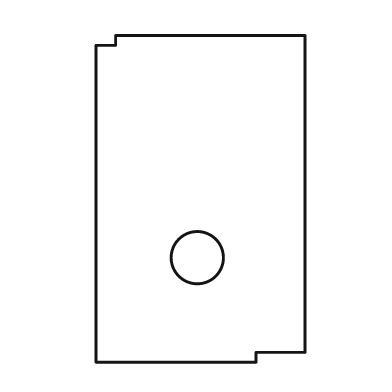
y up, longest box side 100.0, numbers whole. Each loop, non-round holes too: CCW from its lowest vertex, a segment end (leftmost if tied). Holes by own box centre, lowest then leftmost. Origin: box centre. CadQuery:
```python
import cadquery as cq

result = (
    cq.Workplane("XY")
    .moveTo(-32.0, -50.0)
    .lineTo(17.0, -50.0)
    .lineTo(17.0, -47.0)
    .lineTo(32.0, -47.0)
    .lineTo(32.0, 50.0)
    .lineTo(-26.0, 50.0)
    .lineTo(-26.0, 47.0)
    .lineTo(-32.0, 47.0)
    .close()
    .moveTo(-1.0, -18.0)
    .circle(8.0)
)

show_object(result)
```